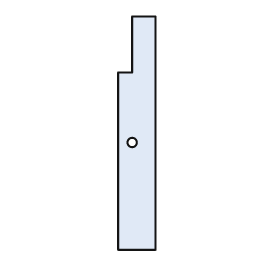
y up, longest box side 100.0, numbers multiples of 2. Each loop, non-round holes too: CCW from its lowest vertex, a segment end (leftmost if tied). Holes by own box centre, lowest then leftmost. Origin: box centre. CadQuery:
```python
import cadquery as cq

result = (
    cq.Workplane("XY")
    .moveTo(-8.0, -50.0)
    .lineTo(8.0, -50.0)
    .lineTo(8.0, 50.0)
    .lineTo(-2.0, 50.0)
    .lineTo(-2.0, 26.0)
    .lineTo(-8.0, 26.0)
    .close()
    .moveTo(-2.0, -4.0)
    .circle(2.0)
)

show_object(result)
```